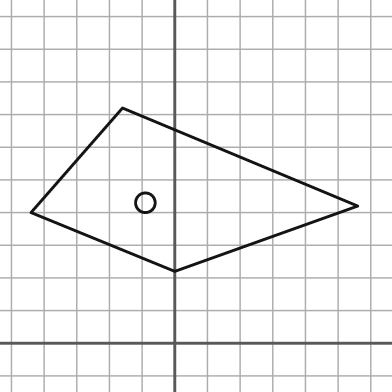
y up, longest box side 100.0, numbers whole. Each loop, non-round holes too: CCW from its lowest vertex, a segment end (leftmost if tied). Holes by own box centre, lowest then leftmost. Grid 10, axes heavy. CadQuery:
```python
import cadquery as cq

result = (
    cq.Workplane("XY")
    .moveTo(0.0, 22.0)
    .lineTo(56.0, 42.0)
    .lineTo(-16.0, 72.0)
    .lineTo(-44.0, 40.0)
    .close()
    .moveTo(-9.0, 43.0)
    .circle(3.0)
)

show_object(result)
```